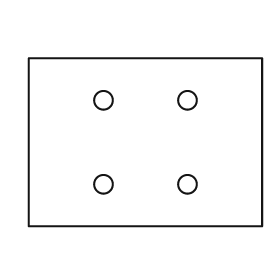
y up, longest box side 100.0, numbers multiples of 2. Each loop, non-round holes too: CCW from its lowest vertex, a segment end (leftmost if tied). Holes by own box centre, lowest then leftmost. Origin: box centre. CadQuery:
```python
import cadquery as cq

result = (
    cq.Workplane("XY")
    .moveTo(-50.0, -36.0)
    .lineTo(50.0, -36.0)
    .lineTo(50.0, 36.0)
    .lineTo(-50.0, 36.0)
    .close()
    .moveTo(-18.0, -18.0)
    .circle(4.0)
    .moveTo(18.0, -18.0)
    .circle(4.0)
    .moveTo(-18.0, 18.0)
    .circle(4.0)
    .moveTo(18.0, 18.0)
    .circle(4.0)
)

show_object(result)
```